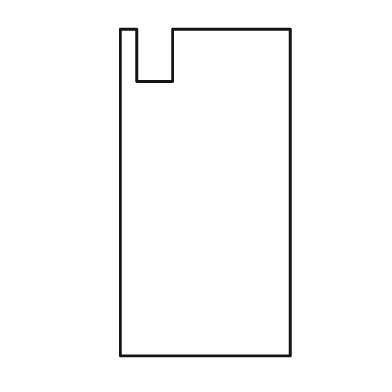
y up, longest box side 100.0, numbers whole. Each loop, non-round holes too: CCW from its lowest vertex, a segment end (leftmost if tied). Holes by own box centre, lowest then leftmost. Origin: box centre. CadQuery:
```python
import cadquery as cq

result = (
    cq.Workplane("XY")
    .moveTo(-26.0, -50.0)
    .lineTo(26.0, -50.0)
    .lineTo(26.0, 50.0)
    .lineTo(-10.0, 50.0)
    .lineTo(-10.0, 34.0)
    .lineTo(-21.0, 34.0)
    .lineTo(-21.0, 50.0)
    .lineTo(-26.0, 50.0)
    .close()
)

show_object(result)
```